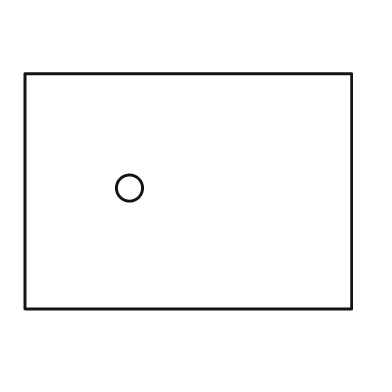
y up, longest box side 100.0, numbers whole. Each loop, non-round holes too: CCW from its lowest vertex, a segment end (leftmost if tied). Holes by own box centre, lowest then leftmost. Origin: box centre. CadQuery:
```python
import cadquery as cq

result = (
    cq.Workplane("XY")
    .moveTo(-50.0, -36.0)
    .lineTo(50.0, -36.0)
    .lineTo(50.0, 36.0)
    .lineTo(-50.0, 36.0)
    .close()
    .moveTo(-18.0, 1.0)
    .circle(4.0)
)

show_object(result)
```